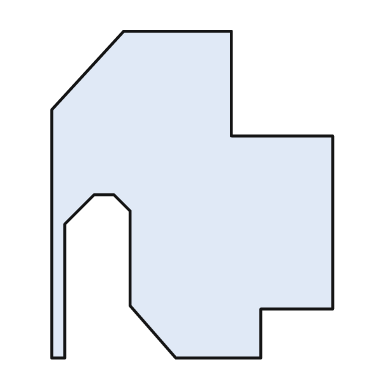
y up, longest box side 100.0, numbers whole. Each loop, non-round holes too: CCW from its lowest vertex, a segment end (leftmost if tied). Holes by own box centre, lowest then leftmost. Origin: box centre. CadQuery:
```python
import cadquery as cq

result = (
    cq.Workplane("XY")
    .moveTo(-43.0, -50.0)
    .lineTo(-39.0, -50.0)
    .lineTo(-39.0, -9.0)
    .lineTo(-30.0, 0.0)
    .lineTo(-24.0, 0.0)
    .lineTo(-19.0, -5.0)
    .lineTo(-19.0, -34.0)
    .lineTo(-5.0, -50.0)
    .lineTo(21.0, -50.0)
    .lineTo(21.0, -35.0)
    .lineTo(43.0, -35.0)
    .lineTo(43.0, 18.0)
    .lineTo(12.0, 18.0)
    .lineTo(12.0, 50.0)
    .lineTo(-21.0, 50.0)
    .lineTo(-43.0, 26.0)
    .close()
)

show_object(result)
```